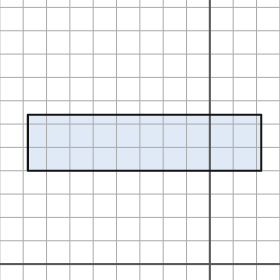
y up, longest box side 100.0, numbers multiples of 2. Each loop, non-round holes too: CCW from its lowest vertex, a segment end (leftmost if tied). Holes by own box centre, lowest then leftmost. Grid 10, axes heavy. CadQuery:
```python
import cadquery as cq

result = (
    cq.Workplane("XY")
    .moveTo(-78.0, 40.0)
    .lineTo(22.0, 40.0)
    .lineTo(22.0, 64.0)
    .lineTo(-78.0, 64.0)
    .close()
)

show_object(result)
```